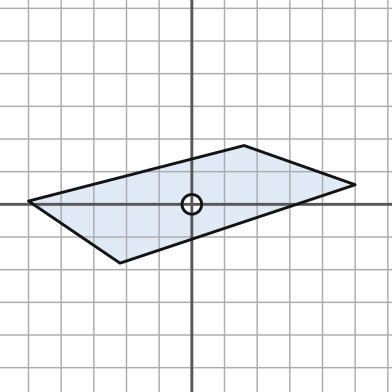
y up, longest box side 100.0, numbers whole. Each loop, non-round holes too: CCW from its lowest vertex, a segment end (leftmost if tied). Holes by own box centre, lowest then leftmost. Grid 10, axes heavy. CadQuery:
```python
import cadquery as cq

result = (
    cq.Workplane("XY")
    .moveTo(-22.0, -18.0)
    .lineTo(50.0, 6.0)
    .lineTo(16.0, 18.0)
    .lineTo(-50.0, 1.0)
    .close()
    .moveTo(0.0, 0.0)
    .circle(3.0)
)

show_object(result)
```